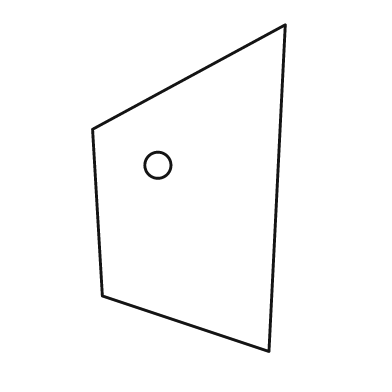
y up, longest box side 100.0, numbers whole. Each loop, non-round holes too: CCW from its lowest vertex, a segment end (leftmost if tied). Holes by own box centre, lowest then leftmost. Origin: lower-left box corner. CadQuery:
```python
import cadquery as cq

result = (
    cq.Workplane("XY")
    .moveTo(54.0, 0.0)
    .lineTo(59.0, 100.0)
    .lineTo(0.0, 68.0)
    .lineTo(3.0, 17.0)
    .close()
    .moveTo(20.0, 57.0)
    .circle(4.0)
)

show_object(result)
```